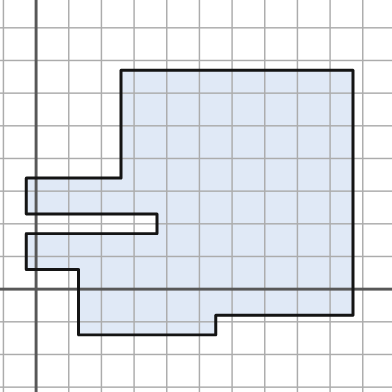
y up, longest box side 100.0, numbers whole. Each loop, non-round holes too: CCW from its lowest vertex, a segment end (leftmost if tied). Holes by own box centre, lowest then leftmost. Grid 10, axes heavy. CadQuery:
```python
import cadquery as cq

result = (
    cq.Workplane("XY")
    .moveTo(13.0, -14.0)
    .lineTo(55.0, -14.0)
    .lineTo(55.0, -8.0)
    .lineTo(97.0, -8.0)
    .lineTo(97.0, 67.0)
    .lineTo(26.0, 67.0)
    .lineTo(26.0, 34.0)
    .lineTo(-3.0, 34.0)
    .lineTo(-3.0, 23.0)
    .lineTo(37.0, 23.0)
    .lineTo(37.0, 17.0)
    .lineTo(-3.0, 17.0)
    .lineTo(-3.0, 6.0)
    .lineTo(13.0, 6.0)
    .close()
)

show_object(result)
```